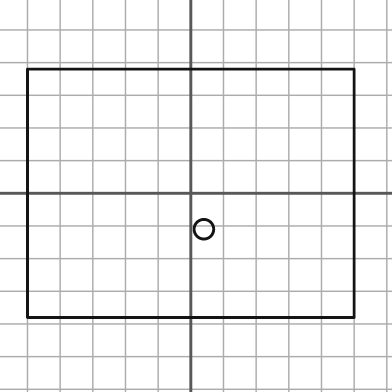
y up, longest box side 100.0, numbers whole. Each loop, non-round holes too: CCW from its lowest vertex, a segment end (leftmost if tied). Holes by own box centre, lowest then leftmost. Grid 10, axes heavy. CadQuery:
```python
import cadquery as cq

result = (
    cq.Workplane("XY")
    .moveTo(-50.0, -38.0)
    .lineTo(50.0, -38.0)
    .lineTo(50.0, 38.0)
    .lineTo(-50.0, 38.0)
    .close()
    .moveTo(4.0, -11.0)
    .circle(3.0)
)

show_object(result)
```